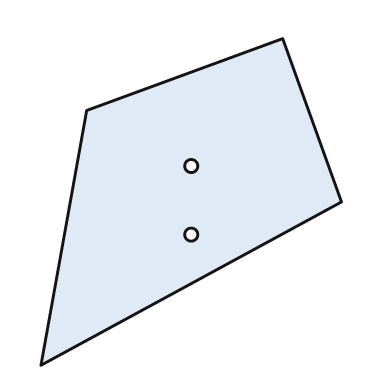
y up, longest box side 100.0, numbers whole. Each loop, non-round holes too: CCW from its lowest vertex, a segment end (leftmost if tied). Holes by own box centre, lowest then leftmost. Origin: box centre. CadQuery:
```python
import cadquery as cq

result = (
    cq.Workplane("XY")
    .moveTo(-46.0, -50.0)
    .lineTo(46.0, 0.0)
    .lineTo(28.0, 50.0)
    .lineTo(-32.0, 28.0)
    .close()
    .moveTo(0.0, -10.0)
    .circle(2.0)
    .moveTo(0.0, 11.0)
    .circle(2.0)
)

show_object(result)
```